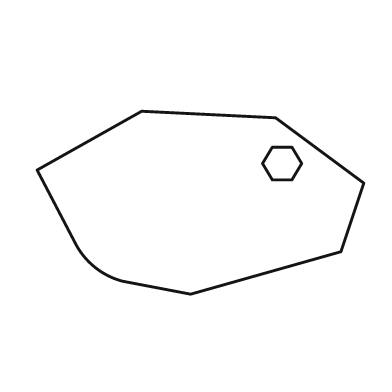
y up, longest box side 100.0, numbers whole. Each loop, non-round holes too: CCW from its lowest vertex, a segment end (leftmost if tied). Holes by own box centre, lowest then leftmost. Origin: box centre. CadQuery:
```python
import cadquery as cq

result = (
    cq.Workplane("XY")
    .moveTo(-3.0, -28.0)
    .lineTo(43.0, -15.0)
    .lineTo(50.0, 6.0)
    .lineTo(23.0, 26.0)
    .lineTo(-18.0, 28.0)
    .lineTo(-50.0, 10.0)
    .lineTo(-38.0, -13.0)
    .threePointArc((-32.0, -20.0), (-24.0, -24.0))
    .close()
    .moveTo(22.0, 7.0)
    .lineTo(28.0, 7.0)
    .lineTo(31.0, 12.0)
    .lineTo(28.0, 17.0)
    .lineTo(22.0, 17.0)
    .lineTo(19.0, 12.0)
    .close()
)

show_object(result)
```